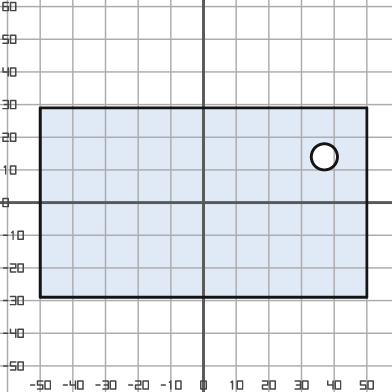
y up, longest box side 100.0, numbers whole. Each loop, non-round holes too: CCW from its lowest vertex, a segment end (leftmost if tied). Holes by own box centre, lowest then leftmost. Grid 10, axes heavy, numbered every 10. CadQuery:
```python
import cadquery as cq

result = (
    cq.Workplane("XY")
    .moveTo(-50.0, -29.0)
    .lineTo(50.0, -29.0)
    .lineTo(50.0, 29.0)
    .lineTo(-50.0, 29.0)
    .close()
    .moveTo(37.0, 14.0)
    .circle(4.0)
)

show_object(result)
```